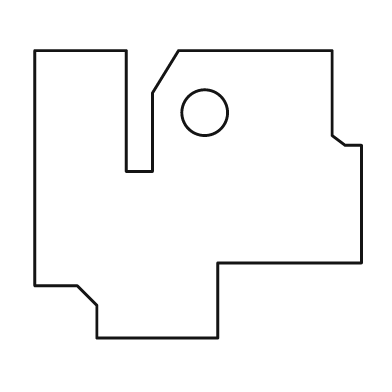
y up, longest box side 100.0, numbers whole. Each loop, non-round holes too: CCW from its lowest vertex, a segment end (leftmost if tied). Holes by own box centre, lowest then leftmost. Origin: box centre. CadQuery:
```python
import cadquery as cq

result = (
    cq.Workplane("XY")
    .moveTo(-31.0, -44.0)
    .lineTo(6.0, -44.0)
    .lineTo(6.0, -21.0)
    .lineTo(50.0, -21.0)
    .lineTo(50.0, 15.0)
    .lineTo(45.0, 15.0)
    .lineTo(41.0, 18.0)
    .lineTo(41.0, 44.0)
    .lineTo(-6.0, 44.0)
    .lineTo(-14.0, 31.0)
    .lineTo(-14.0, 7.0)
    .lineTo(-22.0, 7.0)
    .lineTo(-22.0, 44.0)
    .lineTo(-50.0, 44.0)
    .lineTo(-50.0, -28.0)
    .lineTo(-37.0, -28.0)
    .lineTo(-31.0, -34.0)
    .close()
    .moveTo(2.0, 25.0)
    .circle(7.0)
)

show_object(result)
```